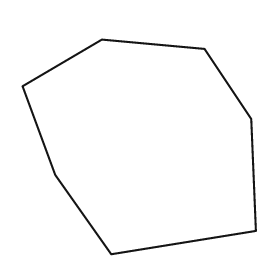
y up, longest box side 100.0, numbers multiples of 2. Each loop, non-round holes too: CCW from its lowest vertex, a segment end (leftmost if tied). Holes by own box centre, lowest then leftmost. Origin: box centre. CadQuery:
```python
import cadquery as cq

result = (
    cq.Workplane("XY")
    .moveTo(-12.0, -46.0)
    .lineTo(50.0, -36.0)
    .lineTo(48.0, 12.0)
    .lineTo(28.0, 42.0)
    .lineTo(-16.0, 46.0)
    .lineTo(-50.0, 26.0)
    .lineTo(-36.0, -12.0)
    .close()
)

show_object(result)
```